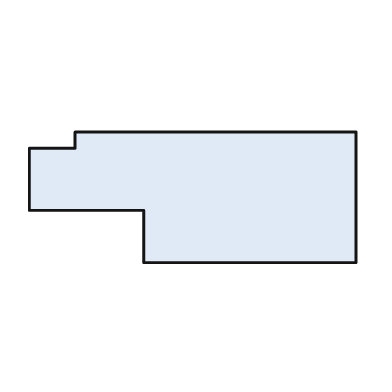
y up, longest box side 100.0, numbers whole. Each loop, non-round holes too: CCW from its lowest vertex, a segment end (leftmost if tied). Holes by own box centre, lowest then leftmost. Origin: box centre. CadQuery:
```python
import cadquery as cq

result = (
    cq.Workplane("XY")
    .moveTo(-15.0, -20.0)
    .lineTo(50.0, -20.0)
    .lineTo(50.0, 20.0)
    .lineTo(-36.0, 20.0)
    .lineTo(-36.0, 15.0)
    .lineTo(-50.0, 15.0)
    .lineTo(-50.0, -4.0)
    .lineTo(-15.0, -4.0)
    .close()
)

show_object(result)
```